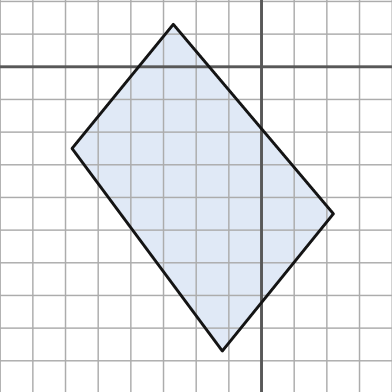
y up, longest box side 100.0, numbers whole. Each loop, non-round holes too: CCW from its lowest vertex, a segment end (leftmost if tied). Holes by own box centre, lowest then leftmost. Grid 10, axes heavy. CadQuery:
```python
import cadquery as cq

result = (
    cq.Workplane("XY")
    .moveTo(-12.0, -87.0)
    .lineTo(22.0, -45.0)
    .lineTo(-27.0, 13.0)
    .lineTo(-58.0, -25.0)
    .close()
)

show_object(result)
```